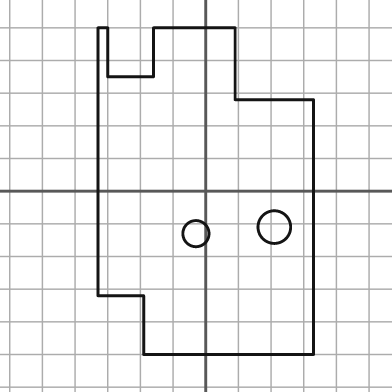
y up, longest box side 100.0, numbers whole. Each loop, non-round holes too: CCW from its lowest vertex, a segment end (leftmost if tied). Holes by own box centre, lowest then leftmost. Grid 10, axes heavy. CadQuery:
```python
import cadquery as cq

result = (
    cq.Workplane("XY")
    .moveTo(-19.0, -50.0)
    .lineTo(33.0, -50.0)
    .lineTo(33.0, 28.0)
    .lineTo(9.0, 28.0)
    .lineTo(9.0, 50.0)
    .lineTo(-16.0, 50.0)
    .lineTo(-16.0, 35.0)
    .lineTo(-30.0, 35.0)
    .lineTo(-30.0, 50.0)
    .lineTo(-33.0, 50.0)
    .lineTo(-33.0, -32.0)
    .lineTo(-19.0, -32.0)
    .close()
    .moveTo(-3.0, -13.0)
    .circle(4.0)
    .moveTo(21.0, -11.0)
    .circle(5.0)
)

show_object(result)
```